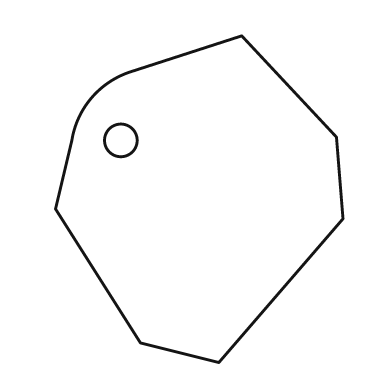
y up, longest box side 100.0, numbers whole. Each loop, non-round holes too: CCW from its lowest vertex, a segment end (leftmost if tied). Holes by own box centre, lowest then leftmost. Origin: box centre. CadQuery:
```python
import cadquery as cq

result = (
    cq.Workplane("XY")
    .moveTo(6.0, -50.0)
    .lineTo(44.0, -6.0)
    .lineTo(42.0, 19.0)
    .lineTo(13.0, 50.0)
    .lineTo(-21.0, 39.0)
    .threePointArc((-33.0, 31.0), (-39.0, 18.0))
    .lineTo(-44.0, -3.0)
    .lineTo(-18.0, -44.0)
    .close()
    .moveTo(-24.0, 18.0)
    .circle(5.0)
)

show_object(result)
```